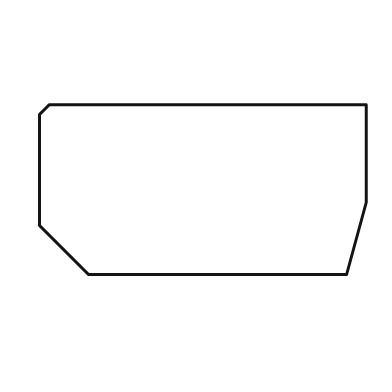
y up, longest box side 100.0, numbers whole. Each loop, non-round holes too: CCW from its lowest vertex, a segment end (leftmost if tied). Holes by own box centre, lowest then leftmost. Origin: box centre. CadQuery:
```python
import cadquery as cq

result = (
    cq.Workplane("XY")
    .moveTo(-35.0, -26.0)
    .lineTo(44.0, -26.0)
    .lineTo(50.0, -4.0)
    .lineTo(50.0, 26.0)
    .lineTo(-47.0, 26.0)
    .lineTo(-50.0, 23.0)
    .lineTo(-50.0, -11.0)
    .close()
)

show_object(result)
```